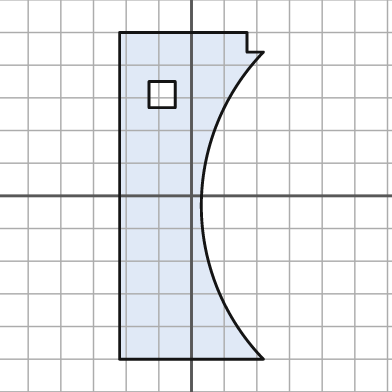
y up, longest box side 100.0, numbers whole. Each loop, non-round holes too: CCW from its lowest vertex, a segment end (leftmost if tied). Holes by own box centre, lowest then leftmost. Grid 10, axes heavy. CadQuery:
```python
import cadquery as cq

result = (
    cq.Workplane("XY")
    .moveTo(-22.0, -50.0)
    .lineTo(22.0, -50.0)
    .threePointArc((3.0, -3.0), (22.0, 44.0))
    .lineTo(17.0, 44.0)
    .lineTo(17.0, 50.0)
    .lineTo(-22.0, 50.0)
    .close()
    .moveTo(-13.0, 27.0)
    .lineTo(-5.0, 27.0)
    .lineTo(-5.0, 35.0)
    .lineTo(-13.0, 35.0)
    .close()
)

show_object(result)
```